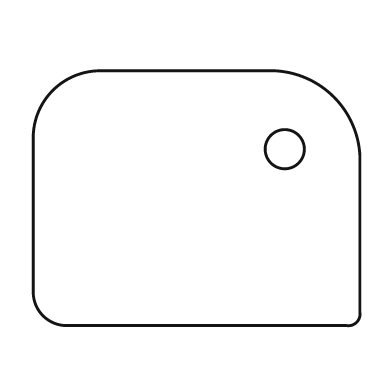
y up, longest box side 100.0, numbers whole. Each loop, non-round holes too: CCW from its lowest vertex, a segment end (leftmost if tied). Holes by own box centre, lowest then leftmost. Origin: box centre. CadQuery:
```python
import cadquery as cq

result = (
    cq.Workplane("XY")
    .moveTo(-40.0, -39.0)
    .lineTo(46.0, -39.0)
    .threePointArc((49.0, -38.0), (50.0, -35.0))
    .lineTo(50.0, 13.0)
    .threePointArc((42.0, 31.0), (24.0, 39.0))
    .lineTo(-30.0, 39.0)
    .threePointArc((-44.0, 33.0), (-50.0, 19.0))
    .lineTo(-50.0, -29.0)
    .threePointArc((-47.0, -36.0), (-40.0, -39.0))
    .close()
    .moveTo(27.0, 15.0)
    .circle(6.0)
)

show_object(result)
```